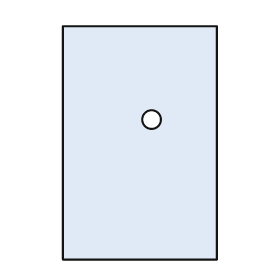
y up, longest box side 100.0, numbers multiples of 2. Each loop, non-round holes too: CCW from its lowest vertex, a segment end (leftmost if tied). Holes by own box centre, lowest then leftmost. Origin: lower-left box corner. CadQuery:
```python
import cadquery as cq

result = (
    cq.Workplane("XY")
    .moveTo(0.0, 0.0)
    .lineTo(66.0, 0.0)
    .lineTo(66.0, 100.0)
    .lineTo(0.0, 100.0)
    .close()
    .moveTo(38.0, 60.0)
    .circle(4.0)
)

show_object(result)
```